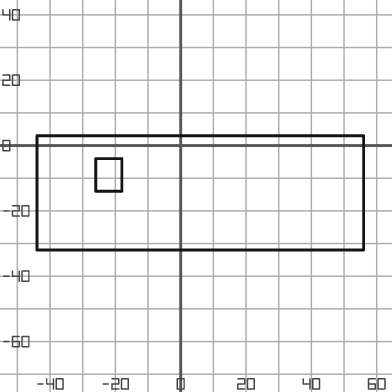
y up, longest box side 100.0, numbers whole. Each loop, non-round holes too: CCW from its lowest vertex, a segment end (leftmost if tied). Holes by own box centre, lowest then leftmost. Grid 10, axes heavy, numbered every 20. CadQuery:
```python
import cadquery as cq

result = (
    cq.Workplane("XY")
    .moveTo(-44.0, -32.0)
    .lineTo(56.0, -32.0)
    .lineTo(56.0, 3.0)
    .lineTo(-44.0, 3.0)
    .close()
    .moveTo(-26.0, -14.0)
    .lineTo(-18.0, -14.0)
    .lineTo(-18.0, -4.0)
    .lineTo(-26.0, -4.0)
    .close()
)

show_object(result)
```